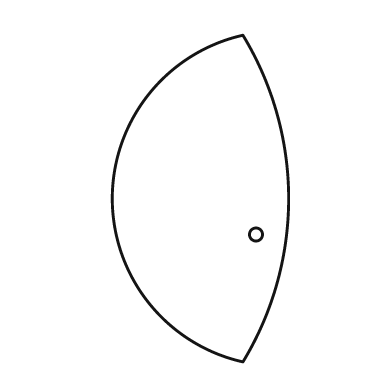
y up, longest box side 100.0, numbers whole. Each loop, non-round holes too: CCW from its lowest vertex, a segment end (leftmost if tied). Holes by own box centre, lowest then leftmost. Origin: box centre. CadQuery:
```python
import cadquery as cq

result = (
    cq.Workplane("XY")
    .moveTo(13.0, -50.0)
    .threePointArc((27.0, 0.0), (13.0, 50.0))
    .threePointArc((-27.0, 0.0), (13.0, -50.0))
    .close()
    .moveTo(17.0, -11.0)
    .circle(2.0)
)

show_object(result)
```